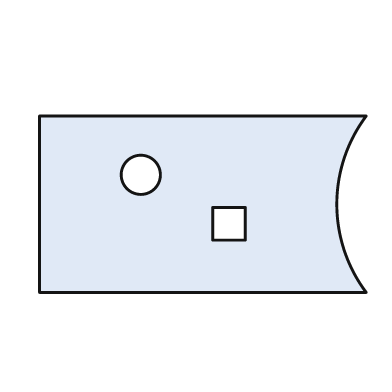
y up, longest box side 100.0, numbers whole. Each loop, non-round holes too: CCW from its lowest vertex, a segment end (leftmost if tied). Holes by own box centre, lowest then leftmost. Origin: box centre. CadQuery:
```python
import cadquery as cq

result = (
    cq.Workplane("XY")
    .moveTo(-50.0, -27.0)
    .lineTo(50.0, -27.0)
    .threePointArc((41.0, 0.0), (50.0, 27.0))
    .lineTo(-50.0, 27.0)
    .close()
    .moveTo(3.0, -11.0)
    .lineTo(13.0, -11.0)
    .lineTo(13.0, -1.0)
    .lineTo(3.0, -1.0)
    .close()
    .moveTo(-19.0, 9.0)
    .circle(6.0)
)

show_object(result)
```